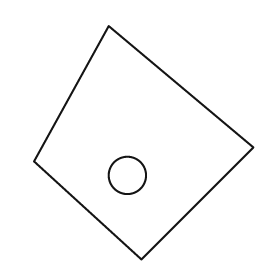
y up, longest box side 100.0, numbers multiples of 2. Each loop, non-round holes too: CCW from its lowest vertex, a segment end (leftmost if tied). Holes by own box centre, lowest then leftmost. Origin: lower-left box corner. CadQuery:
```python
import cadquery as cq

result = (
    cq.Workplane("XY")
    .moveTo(46.0, 0.0)
    .lineTo(94.0, 48.0)
    .lineTo(32.0, 100.0)
    .lineTo(0.0, 42.0)
    .close()
    .moveTo(40.0, 36.0)
    .circle(8.0)
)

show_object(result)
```